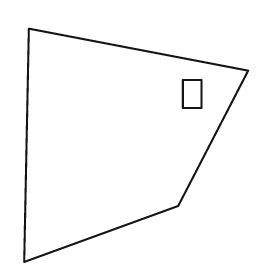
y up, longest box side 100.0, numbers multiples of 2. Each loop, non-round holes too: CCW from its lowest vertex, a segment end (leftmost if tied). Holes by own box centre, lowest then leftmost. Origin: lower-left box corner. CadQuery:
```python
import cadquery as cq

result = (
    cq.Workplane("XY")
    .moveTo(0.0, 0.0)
    .lineTo(66.0, 24.0)
    .lineTo(96.0, 82.0)
    .lineTo(2.0, 100.0)
    .close()
    .moveTo(68.0, 66.0)
    .lineTo(76.0, 66.0)
    .lineTo(76.0, 78.0)
    .lineTo(68.0, 78.0)
    .close()
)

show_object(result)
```